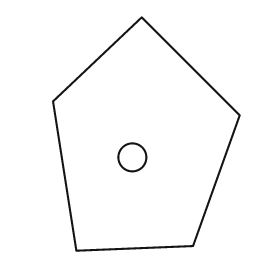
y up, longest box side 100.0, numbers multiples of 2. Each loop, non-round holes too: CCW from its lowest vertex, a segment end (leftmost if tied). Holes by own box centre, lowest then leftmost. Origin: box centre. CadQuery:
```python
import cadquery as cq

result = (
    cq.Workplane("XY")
    .moveTo(-30.0, -50.0)
    .lineTo(20.0, -48.0)
    .lineTo(40.0, 8.0)
    .lineTo(-2.0, 50.0)
    .lineTo(-40.0, 14.0)
    .close()
    .moveTo(-6.0, -10.0)
    .circle(6.0)
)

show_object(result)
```